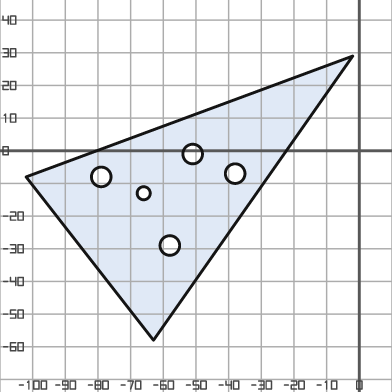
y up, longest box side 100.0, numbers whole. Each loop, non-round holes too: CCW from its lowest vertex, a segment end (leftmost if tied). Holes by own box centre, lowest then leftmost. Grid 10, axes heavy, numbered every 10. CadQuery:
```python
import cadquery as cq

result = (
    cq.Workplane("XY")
    .moveTo(-63.0, -58.0)
    .lineTo(-2.0, 29.0)
    .lineTo(-102.0, -8.0)
    .close()
    .moveTo(-58.0, -29.0)
    .circle(3.0)
    .moveTo(-66.0, -13.0)
    .circle(2.0)
    .moveTo(-79.0, -8.0)
    .circle(3.0)
    .moveTo(-38.0, -7.0)
    .circle(3.0)
    .moveTo(-51.0, -1.0)
    .circle(3.0)
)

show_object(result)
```